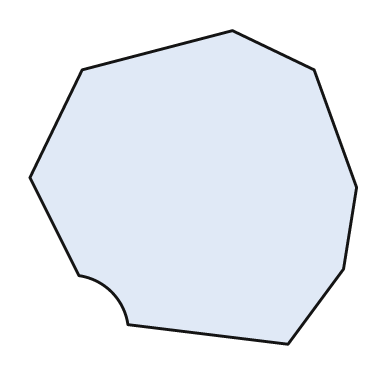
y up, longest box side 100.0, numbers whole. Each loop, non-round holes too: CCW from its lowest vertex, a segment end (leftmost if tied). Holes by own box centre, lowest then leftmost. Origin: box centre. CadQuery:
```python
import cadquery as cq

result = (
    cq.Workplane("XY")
    .moveTo(29.0, -48.0)
    .lineTo(46.0, -25.0)
    .lineTo(50.0, 0.0)
    .lineTo(37.0, 36.0)
    .lineTo(12.0, 48.0)
    .lineTo(-34.0, 36.0)
    .lineTo(-50.0, 3.0)
    .lineTo(-35.0, -27.0)
    .threePointArc((-25.0, -32.0), (-20.0, -42.0))
    .close()
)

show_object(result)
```